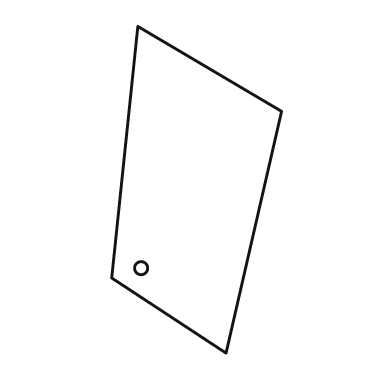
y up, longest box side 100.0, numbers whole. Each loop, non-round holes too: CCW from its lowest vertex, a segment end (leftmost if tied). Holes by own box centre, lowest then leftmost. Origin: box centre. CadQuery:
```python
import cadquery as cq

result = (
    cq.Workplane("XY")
    .moveTo(9.0, -50.0)
    .lineTo(26.0, 24.0)
    .lineTo(-18.0, 50.0)
    .lineTo(-26.0, -27.0)
    .close()
    .moveTo(-17.0, -24.0)
    .circle(2.0)
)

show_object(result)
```